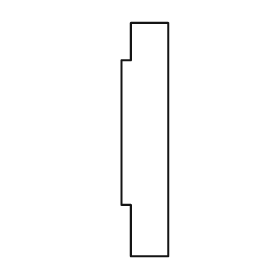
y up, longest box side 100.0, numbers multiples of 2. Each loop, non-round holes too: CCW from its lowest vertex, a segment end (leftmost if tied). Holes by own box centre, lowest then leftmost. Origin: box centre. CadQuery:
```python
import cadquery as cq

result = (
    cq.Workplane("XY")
    .moveTo(-6.0, -50.0)
    .lineTo(10.0, -50.0)
    .lineTo(10.0, 50.0)
    .lineTo(-6.0, 50.0)
    .lineTo(-6.0, 34.0)
    .lineTo(-10.0, 34.0)
    .lineTo(-10.0, -28.0)
    .lineTo(-6.0, -28.0)
    .close()
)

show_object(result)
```